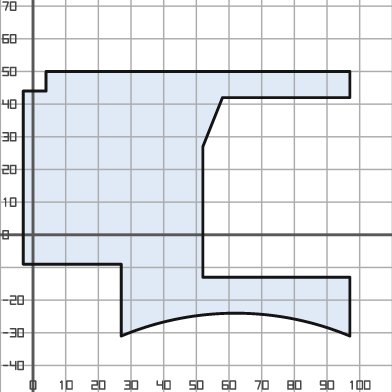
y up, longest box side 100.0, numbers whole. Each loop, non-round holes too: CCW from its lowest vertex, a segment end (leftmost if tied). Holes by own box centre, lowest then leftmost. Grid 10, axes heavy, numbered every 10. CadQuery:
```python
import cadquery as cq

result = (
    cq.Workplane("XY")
    .moveTo(27.0, -31.0)
    .threePointArc((62.0, -24.0), (97.0, -31.0))
    .lineTo(97.0, -13.0)
    .lineTo(52.0, -13.0)
    .lineTo(52.0, 27.0)
    .lineTo(58.0, 42.0)
    .lineTo(97.0, 42.0)
    .lineTo(97.0, 50.0)
    .lineTo(4.0, 50.0)
    .lineTo(4.0, 44.0)
    .lineTo(-3.0, 44.0)
    .lineTo(-3.0, -9.0)
    .lineTo(27.0, -9.0)
    .close()
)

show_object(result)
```